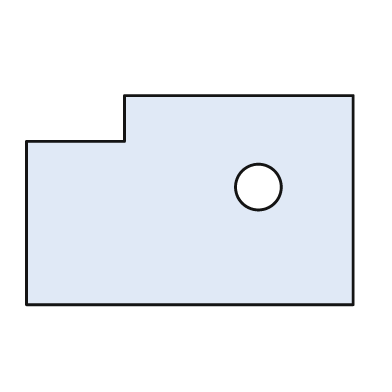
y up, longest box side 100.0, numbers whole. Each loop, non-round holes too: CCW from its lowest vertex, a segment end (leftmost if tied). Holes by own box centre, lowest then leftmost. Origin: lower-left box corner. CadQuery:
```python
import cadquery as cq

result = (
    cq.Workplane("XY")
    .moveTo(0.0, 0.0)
    .lineTo(100.0, 0.0)
    .lineTo(100.0, 64.0)
    .lineTo(30.0, 64.0)
    .lineTo(30.0, 50.0)
    .lineTo(0.0, 50.0)
    .close()
    .moveTo(71.0, 36.0)
    .circle(7.0)
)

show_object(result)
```